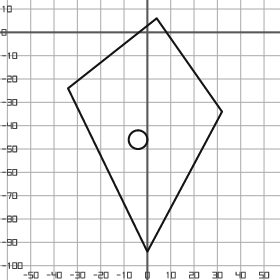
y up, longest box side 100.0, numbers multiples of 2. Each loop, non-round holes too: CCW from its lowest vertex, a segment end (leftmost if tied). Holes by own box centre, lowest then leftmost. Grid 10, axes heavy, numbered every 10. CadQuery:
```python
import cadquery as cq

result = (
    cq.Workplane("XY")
    .moveTo(0.0, -94.0)
    .lineTo(32.0, -34.0)
    .lineTo(4.0, 6.0)
    .lineTo(-34.0, -24.0)
    .close()
    .moveTo(-4.0, -46.0)
    .circle(4.0)
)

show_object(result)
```